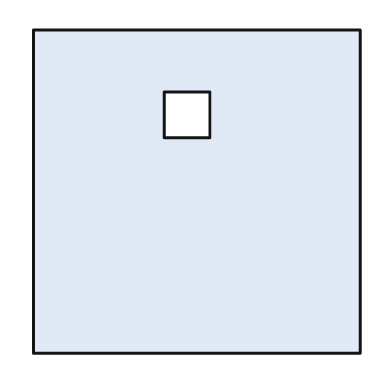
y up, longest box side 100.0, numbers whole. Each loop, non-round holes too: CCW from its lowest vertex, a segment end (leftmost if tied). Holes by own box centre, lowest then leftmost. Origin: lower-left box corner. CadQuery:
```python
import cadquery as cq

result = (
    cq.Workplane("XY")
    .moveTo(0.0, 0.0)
    .lineTo(100.0, 0.0)
    .lineTo(100.0, 99.0)
    .lineTo(0.0, 99.0)
    .close()
    .moveTo(40.0, 66.0)
    .lineTo(54.0, 66.0)
    .lineTo(54.0, 80.0)
    .lineTo(40.0, 80.0)
    .close()
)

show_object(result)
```